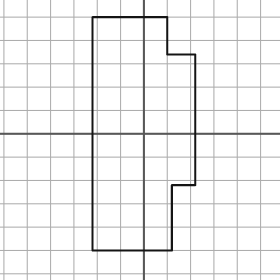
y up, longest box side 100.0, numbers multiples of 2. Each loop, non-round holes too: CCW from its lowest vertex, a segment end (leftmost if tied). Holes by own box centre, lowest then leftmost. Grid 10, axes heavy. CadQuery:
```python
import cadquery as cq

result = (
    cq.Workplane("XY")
    .moveTo(-22.0, -50.0)
    .lineTo(12.0, -50.0)
    .lineTo(12.0, -22.0)
    .lineTo(22.0, -22.0)
    .lineTo(22.0, 34.0)
    .lineTo(10.0, 34.0)
    .lineTo(10.0, 50.0)
    .lineTo(-22.0, 50.0)
    .close()
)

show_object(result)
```